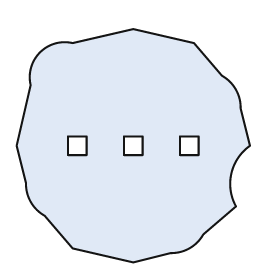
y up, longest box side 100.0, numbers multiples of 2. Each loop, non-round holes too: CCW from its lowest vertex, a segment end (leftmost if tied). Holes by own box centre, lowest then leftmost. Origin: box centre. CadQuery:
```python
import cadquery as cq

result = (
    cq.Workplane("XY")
    .moveTo(0.0, -50.0)
    .lineTo(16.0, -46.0)
    .threePointArc((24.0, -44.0), (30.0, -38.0))
    .lineTo(44.0, -26.0)
    .threePointArc((42.0, -12.0), (50.0, 0.0))
    .lineTo(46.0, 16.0)
    .threePointArc((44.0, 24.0), (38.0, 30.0))
    .lineTo(26.0, 44.0)
    .lineTo(0.0, 50.0)
    .lineTo(-26.0, 44.0)
    .threePointArc((-40.0, 40.0), (-44.0, 26.0))
    .lineTo(-50.0, 0.0)
    .lineTo(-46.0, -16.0)
    .threePointArc((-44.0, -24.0), (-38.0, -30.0))
    .lineTo(-26.0, -44.0)
    .close()
    .moveTo(-28.0, -4.0)
    .lineTo(-20.0, -4.0)
    .lineTo(-20.0, 4.0)
    .lineTo(-28.0, 4.0)
    .close()
    .moveTo(-4.0, -4.0)
    .lineTo(4.0, -4.0)
    .lineTo(4.0, 4.0)
    .lineTo(-4.0, 4.0)
    .close()
    .moveTo(20.0, -4.0)
    .lineTo(28.0, -4.0)
    .lineTo(28.0, 4.0)
    .lineTo(20.0, 4.0)
    .close()
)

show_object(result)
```